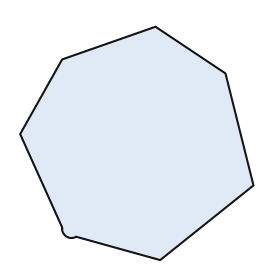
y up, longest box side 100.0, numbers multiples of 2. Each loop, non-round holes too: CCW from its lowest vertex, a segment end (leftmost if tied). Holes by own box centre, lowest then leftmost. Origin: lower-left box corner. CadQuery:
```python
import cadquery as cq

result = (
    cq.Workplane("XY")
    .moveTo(60.0, 0.0)
    .lineTo(100.0, 32.0)
    .lineTo(88.0, 80.0)
    .lineTo(58.0, 100.0)
    .lineTo(18.0, 86.0)
    .lineTo(0.0, 54.0)
    .lineTo(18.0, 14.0)
    .threePointArc((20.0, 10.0), (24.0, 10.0))
    .close()
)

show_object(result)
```